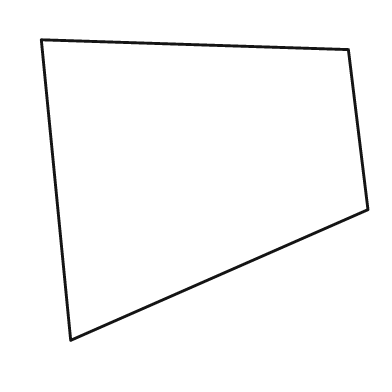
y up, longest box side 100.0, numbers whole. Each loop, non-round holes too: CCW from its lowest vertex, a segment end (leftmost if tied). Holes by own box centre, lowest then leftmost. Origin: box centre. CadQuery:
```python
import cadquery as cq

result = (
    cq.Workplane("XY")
    .moveTo(-41.0, -46.0)
    .lineTo(50.0, -6.0)
    .lineTo(44.0, 43.0)
    .lineTo(-50.0, 46.0)
    .close()
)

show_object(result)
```